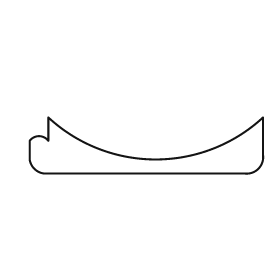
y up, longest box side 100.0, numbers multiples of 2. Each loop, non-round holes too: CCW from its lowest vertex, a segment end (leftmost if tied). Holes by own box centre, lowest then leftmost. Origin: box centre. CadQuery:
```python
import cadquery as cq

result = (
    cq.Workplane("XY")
    .moveTo(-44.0, -12.0)
    .lineTo(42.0, -12.0)
    .threePointArc((48.0, -10.0), (50.0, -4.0))
    .lineTo(50.0, 12.0)
    .threePointArc((4.0, -6.0), (-42.0, 12.0))
    .lineTo(-42.0, 2.0)
    .threePointArc((-46.0, 4.0), (-50.0, 2.0))
    .lineTo(-50.0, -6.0)
    .threePointArc((-48.0, -10.0), (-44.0, -12.0))
    .close()
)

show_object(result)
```